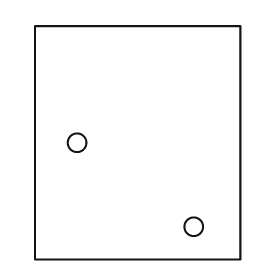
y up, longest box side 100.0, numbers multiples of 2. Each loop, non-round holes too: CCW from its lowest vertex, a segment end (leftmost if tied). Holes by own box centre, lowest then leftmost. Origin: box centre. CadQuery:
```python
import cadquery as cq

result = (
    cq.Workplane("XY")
    .moveTo(-44.0, -50.0)
    .lineTo(44.0, -50.0)
    .lineTo(44.0, 50.0)
    .lineTo(-44.0, 50.0)
    .close()
    .moveTo(24.0, -36.0)
    .circle(4.0)
    .moveTo(-26.0, 0.0)
    .circle(4.0)
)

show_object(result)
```